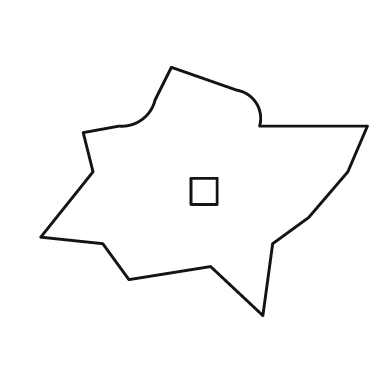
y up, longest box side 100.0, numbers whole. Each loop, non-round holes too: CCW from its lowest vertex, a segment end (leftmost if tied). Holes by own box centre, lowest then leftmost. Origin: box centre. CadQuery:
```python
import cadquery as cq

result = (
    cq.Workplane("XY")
    .moveTo(18.0, -38.0)
    .lineTo(21.0, -16.0)
    .lineTo(32.0, -8.0)
    .lineTo(44.0, 6.0)
    .lineTo(50.0, 20.0)
    .lineTo(17.0, 20.0)
    .threePointArc((16.0, 27.0), (10.0, 31.0))
    .lineTo(-10.0, 38.0)
    .lineTo(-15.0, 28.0)
    .threePointArc((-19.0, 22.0), (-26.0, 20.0))
    .lineTo(-37.0, 18.0)
    .lineTo(-34.0, 6.0)
    .lineTo(-50.0, -14.0)
    .lineTo(-31.0, -16.0)
    .lineTo(-23.0, -27.0)
    .lineTo(2.0, -23.0)
    .close()
    .moveTo(-4.0, -4.0)
    .lineTo(4.0, -4.0)
    .lineTo(4.0, 4.0)
    .lineTo(-4.0, 4.0)
    .close()
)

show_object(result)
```